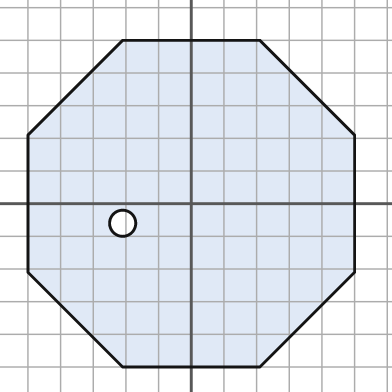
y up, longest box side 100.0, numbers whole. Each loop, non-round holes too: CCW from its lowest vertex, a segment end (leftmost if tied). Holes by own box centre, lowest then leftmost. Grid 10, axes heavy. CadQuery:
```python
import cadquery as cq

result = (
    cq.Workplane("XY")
    .moveTo(-21.0, -50.0)
    .lineTo(21.0, -50.0)
    .lineTo(50.0, -21.0)
    .lineTo(50.0, 21.0)
    .lineTo(21.0, 50.0)
    .lineTo(-21.0, 50.0)
    .lineTo(-50.0, 21.0)
    .lineTo(-50.0, -21.0)
    .close()
    .moveTo(-21.0, -6.0)
    .circle(4.0)
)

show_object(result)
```